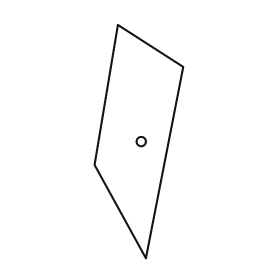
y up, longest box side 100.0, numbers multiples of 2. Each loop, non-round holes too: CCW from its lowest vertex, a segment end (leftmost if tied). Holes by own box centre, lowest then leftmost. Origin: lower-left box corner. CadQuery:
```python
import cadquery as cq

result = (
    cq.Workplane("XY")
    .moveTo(22.0, 0.0)
    .lineTo(38.0, 82.0)
    .lineTo(10.0, 100.0)
    .lineTo(0.0, 40.0)
    .close()
    .moveTo(20.0, 50.0)
    .circle(2.0)
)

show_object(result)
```